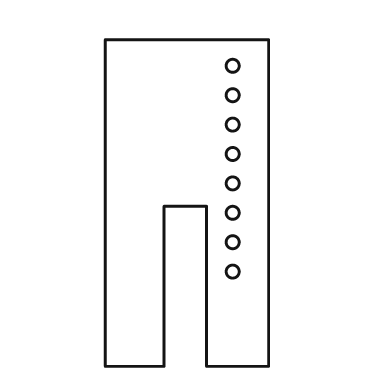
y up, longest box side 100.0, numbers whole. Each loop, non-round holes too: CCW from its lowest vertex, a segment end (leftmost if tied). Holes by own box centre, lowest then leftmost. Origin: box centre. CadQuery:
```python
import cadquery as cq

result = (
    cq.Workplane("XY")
    .moveTo(-25.0, -50.0)
    .lineTo(-7.0, -50.0)
    .lineTo(-7.0, -1.0)
    .lineTo(6.0, -1.0)
    .lineTo(6.0, -50.0)
    .lineTo(25.0, -50.0)
    .lineTo(25.0, 50.0)
    .lineTo(-25.0, 50.0)
    .close()
    .moveTo(14.0, -21.0)
    .circle(2.0)
    .moveTo(14.0, -12.0)
    .circle(2.0)
    .moveTo(14.0, -3.0)
    .circle(2.0)
    .moveTo(14.0, 6.0)
    .circle(2.0)
    .moveTo(14.0, 15.0)
    .circle(2.0)
    .moveTo(14.0, 24.0)
    .circle(2.0)
    .moveTo(14.0, 33.0)
    .circle(2.0)
    .moveTo(14.0, 42.0)
    .circle(2.0)
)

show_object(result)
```